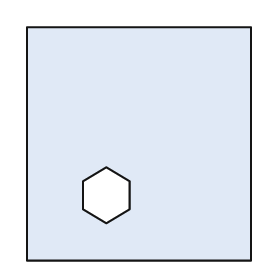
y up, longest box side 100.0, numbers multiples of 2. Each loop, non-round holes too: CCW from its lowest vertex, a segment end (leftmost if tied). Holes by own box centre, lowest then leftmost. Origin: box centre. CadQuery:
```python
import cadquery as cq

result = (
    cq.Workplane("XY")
    .moveTo(-48.0, -50.0)
    .lineTo(48.0, -50.0)
    .lineTo(48.0, 50.0)
    .lineTo(-48.0, 50.0)
    .close()
    .moveTo(-14.0, -34.0)
    .lineTo(-4.0, -28.0)
    .lineTo(-4.0, -16.0)
    .lineTo(-14.0, -10.0)
    .lineTo(-24.0, -16.0)
    .lineTo(-24.0, -28.0)
    .close()
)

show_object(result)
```